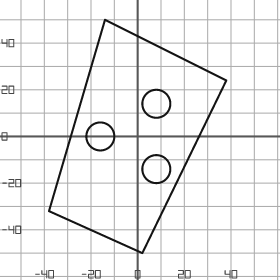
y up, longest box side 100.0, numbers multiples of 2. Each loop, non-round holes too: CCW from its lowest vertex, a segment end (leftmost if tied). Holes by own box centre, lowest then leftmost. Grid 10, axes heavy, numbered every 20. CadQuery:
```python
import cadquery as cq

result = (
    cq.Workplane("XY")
    .moveTo(2.0, -50.0)
    .lineTo(38.0, 24.0)
    .lineTo(-14.0, 50.0)
    .lineTo(-38.0, -32.0)
    .close()
    .moveTo(8.0, -14.0)
    .circle(6.0)
    .moveTo(-16.0, 0.0)
    .circle(6.0)
    .moveTo(8.0, 14.0)
    .circle(6.0)
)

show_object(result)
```